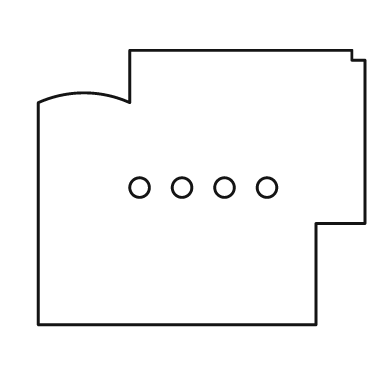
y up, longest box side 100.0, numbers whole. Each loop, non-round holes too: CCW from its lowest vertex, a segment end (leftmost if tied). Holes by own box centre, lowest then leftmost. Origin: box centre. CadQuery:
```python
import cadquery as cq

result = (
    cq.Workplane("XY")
    .moveTo(-50.0, -42.0)
    .lineTo(35.0, -42.0)
    .lineTo(35.0, -11.0)
    .lineTo(50.0, -11.0)
    .lineTo(50.0, 39.0)
    .lineTo(46.0, 39.0)
    .lineTo(46.0, 42.0)
    .lineTo(-22.0, 42.0)
    .lineTo(-22.0, 26.0)
    .threePointArc((-36.0, 29.0), (-50.0, 26.0))
    .close()
    .moveTo(-19.0, 0.0)
    .circle(3.0)
    .moveTo(-6.0, 0.0)
    .circle(3.0)
    .moveTo(7.0, 0.0)
    .circle(3.0)
    .moveTo(20.0, 0.0)
    .circle(3.0)
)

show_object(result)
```